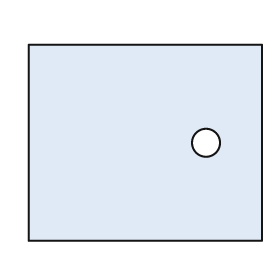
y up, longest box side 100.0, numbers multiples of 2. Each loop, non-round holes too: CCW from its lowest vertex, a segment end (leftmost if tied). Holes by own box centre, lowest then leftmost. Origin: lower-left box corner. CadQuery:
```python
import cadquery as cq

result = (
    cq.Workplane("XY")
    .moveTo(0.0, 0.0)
    .lineTo(100.0, 0.0)
    .lineTo(100.0, 84.0)
    .lineTo(0.0, 84.0)
    .close()
    .moveTo(76.0, 42.0)
    .circle(6.0)
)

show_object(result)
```